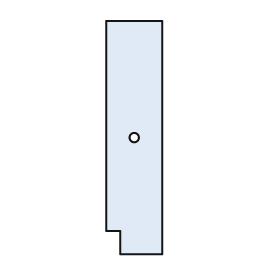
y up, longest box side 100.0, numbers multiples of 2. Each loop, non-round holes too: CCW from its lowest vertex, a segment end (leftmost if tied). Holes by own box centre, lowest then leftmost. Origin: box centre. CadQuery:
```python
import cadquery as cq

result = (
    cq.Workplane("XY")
    .moveTo(-6.0, -50.0)
    .lineTo(12.0, -50.0)
    .lineTo(12.0, 50.0)
    .lineTo(-12.0, 50.0)
    .lineTo(-12.0, -40.0)
    .lineTo(-6.0, -40.0)
    .close()
    .moveTo(0.0, 0.0)
    .circle(2.0)
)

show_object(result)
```